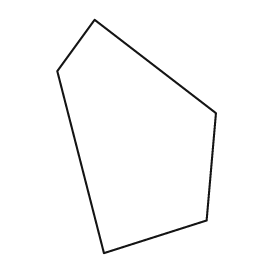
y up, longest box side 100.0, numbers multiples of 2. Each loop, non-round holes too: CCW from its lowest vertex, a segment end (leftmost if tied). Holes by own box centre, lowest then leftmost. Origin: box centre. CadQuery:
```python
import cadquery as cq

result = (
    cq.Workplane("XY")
    .moveTo(-14.0, -50.0)
    .lineTo(30.0, -36.0)
    .lineTo(34.0, 10.0)
    .lineTo(-18.0, 50.0)
    .lineTo(-34.0, 28.0)
    .close()
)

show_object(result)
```